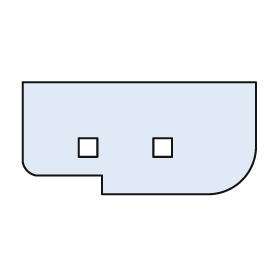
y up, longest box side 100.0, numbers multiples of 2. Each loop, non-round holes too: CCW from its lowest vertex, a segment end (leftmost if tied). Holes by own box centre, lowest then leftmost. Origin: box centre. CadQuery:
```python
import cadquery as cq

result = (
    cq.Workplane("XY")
    .moveTo(-16.0, -24.0)
    .lineTo(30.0, -24.0)
    .threePointArc((44.0, -18.0), (50.0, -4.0))
    .lineTo(50.0, 24.0)
    .lineTo(-50.0, 24.0)
    .lineTo(-50.0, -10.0)
    .threePointArc((-48.0, -14.0), (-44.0, -16.0))
    .lineTo(-16.0, -16.0)
    .close()
    .moveTo(-26.0, -8.0)
    .lineTo(-18.0, -8.0)
    .lineTo(-18.0, 0.0)
    .lineTo(-26.0, 0.0)
    .close()
    .moveTo(6.0, -8.0)
    .lineTo(14.0, -8.0)
    .lineTo(14.0, 0.0)
    .lineTo(6.0, 0.0)
    .close()
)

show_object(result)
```